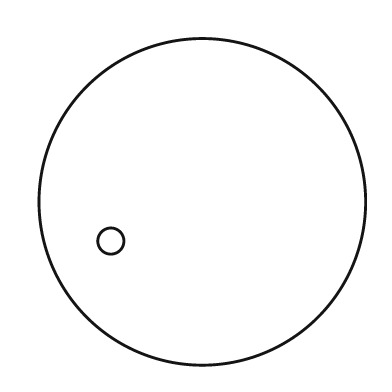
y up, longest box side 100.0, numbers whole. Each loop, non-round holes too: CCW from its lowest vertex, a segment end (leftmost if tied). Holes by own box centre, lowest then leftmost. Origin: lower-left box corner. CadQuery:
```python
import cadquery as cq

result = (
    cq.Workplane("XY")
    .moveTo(50.0, 50.0)
    .circle(50.0)
    .moveTo(22.0, 38.0)
    .circle(4.0)
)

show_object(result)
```